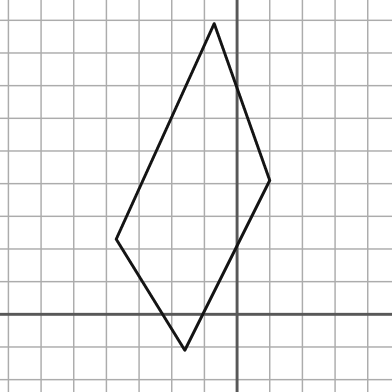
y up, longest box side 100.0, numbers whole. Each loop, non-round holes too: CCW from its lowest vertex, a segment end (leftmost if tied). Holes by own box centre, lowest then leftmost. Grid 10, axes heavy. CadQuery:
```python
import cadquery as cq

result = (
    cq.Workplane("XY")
    .moveTo(-16.0, -11.0)
    .lineTo(10.0, 41.0)
    .lineTo(-7.0, 89.0)
    .lineTo(-37.0, 23.0)
    .close()
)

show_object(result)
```